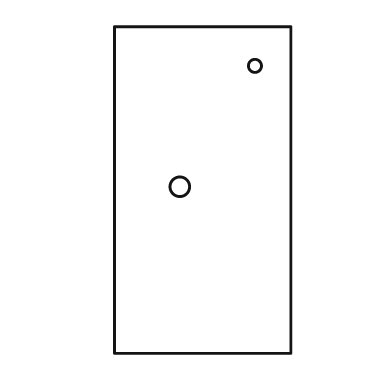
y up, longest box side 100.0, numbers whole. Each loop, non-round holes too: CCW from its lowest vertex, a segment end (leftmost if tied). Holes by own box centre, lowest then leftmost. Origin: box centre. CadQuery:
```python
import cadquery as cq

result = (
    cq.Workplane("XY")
    .moveTo(-27.0, -50.0)
    .lineTo(27.0, -50.0)
    .lineTo(27.0, 50.0)
    .lineTo(-27.0, 50.0)
    .close()
    .moveTo(-7.0, 1.0)
    .circle(3.0)
    .moveTo(16.0, 38.0)
    .circle(2.0)
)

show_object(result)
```